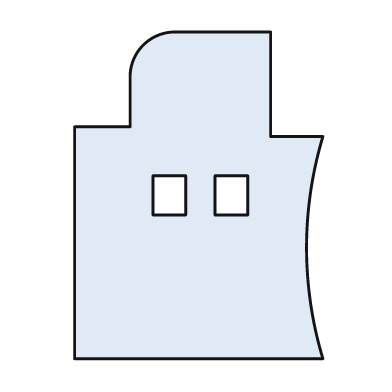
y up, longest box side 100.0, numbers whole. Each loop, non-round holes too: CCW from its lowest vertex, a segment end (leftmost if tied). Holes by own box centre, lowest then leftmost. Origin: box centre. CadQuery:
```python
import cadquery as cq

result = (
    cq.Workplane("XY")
    .moveTo(-38.0, -50.0)
    .lineTo(38.0, -50.0)
    .threePointArc((33.0, -16.0), (38.0, 18.0))
    .lineTo(22.0, 18.0)
    .lineTo(22.0, 50.0)
    .lineTo(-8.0, 50.0)
    .threePointArc((-17.0, 46.0), (-21.0, 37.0))
    .lineTo(-21.0, 21.0)
    .lineTo(-38.0, 21.0)
    .close()
    .moveTo(-14.0, -6.0)
    .lineTo(-4.0, -6.0)
    .lineTo(-4.0, 6.0)
    .lineTo(-14.0, 6.0)
    .close()
    .moveTo(5.0, -6.0)
    .lineTo(15.0, -6.0)
    .lineTo(15.0, 6.0)
    .lineTo(5.0, 6.0)
    .close()
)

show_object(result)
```